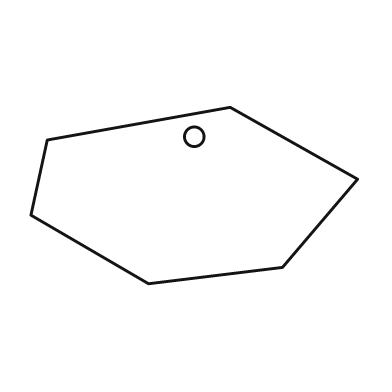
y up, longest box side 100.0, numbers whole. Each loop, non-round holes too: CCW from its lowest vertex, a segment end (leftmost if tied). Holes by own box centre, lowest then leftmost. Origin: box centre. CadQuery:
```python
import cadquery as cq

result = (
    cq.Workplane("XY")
    .moveTo(-14.0, -27.0)
    .lineTo(27.0, -22.0)
    .lineTo(50.0, 5.0)
    .lineTo(11.0, 27.0)
    .lineTo(-45.0, 17.0)
    .lineTo(-50.0, -6.0)
    .close()
    .moveTo(0.0, 18.0)
    .circle(3.0)
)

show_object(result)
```